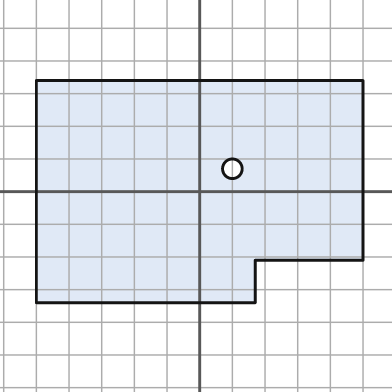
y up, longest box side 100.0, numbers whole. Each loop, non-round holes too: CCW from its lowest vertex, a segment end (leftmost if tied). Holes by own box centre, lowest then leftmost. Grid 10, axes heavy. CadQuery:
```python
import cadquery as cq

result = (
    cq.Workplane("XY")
    .moveTo(-50.0, -34.0)
    .lineTo(17.0, -34.0)
    .lineTo(17.0, -21.0)
    .lineTo(50.0, -21.0)
    .lineTo(50.0, 34.0)
    .lineTo(-50.0, 34.0)
    .close()
    .moveTo(10.0, 7.0)
    .circle(3.0)
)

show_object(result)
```